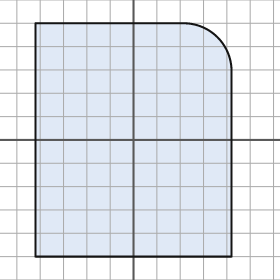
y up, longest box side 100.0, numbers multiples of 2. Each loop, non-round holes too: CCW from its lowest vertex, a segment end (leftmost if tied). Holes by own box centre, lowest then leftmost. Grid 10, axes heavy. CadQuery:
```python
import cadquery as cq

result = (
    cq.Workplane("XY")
    .moveTo(-42.0, -50.0)
    .lineTo(42.0, -50.0)
    .lineTo(42.0, 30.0)
    .threePointArc((36.0, 44.0), (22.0, 50.0))
    .lineTo(-42.0, 50.0)
    .close()
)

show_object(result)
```